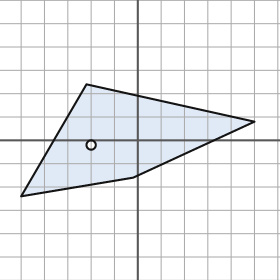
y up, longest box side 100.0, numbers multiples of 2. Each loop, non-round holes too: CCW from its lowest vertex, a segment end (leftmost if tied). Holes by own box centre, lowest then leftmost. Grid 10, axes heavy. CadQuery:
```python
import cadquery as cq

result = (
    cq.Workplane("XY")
    .moveTo(-50.0, -24.0)
    .lineTo(-2.0, -16.0)
    .lineTo(50.0, 8.0)
    .lineTo(-22.0, 24.0)
    .close()
    .moveTo(-20.0, -2.0)
    .circle(2.0)
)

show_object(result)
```